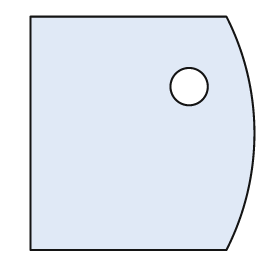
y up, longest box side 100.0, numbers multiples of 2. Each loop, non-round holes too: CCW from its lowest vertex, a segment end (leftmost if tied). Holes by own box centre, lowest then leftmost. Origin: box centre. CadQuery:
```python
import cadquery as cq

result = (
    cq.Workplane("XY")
    .moveTo(-48.0, -50.0)
    .lineTo(36.0, -50.0)
    .threePointArc((48.0, 0.0), (36.0, 50.0))
    .lineTo(-48.0, 50.0)
    .close()
    .moveTo(20.0, 20.0)
    .circle(8.0)
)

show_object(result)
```